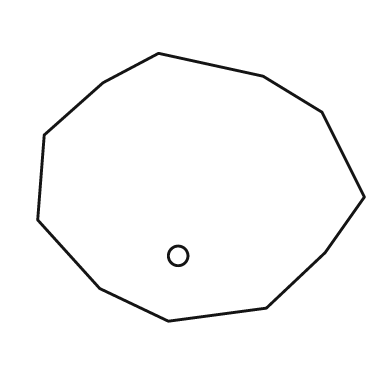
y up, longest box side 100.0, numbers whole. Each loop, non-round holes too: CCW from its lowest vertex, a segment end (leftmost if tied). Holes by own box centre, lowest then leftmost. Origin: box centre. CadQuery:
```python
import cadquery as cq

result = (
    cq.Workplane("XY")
    .moveTo(-10.0, -41.0)
    .lineTo(20.0, -37.0)
    .lineTo(38.0, -20.0)
    .lineTo(50.0, -3.0)
    .lineTo(37.0, 23.0)
    .lineTo(19.0, 34.0)
    .lineTo(-13.0, 41.0)
    .lineTo(-30.0, 32.0)
    .lineTo(-48.0, 16.0)
    .lineTo(-50.0, -10.0)
    .lineTo(-31.0, -31.0)
    .close()
    .moveTo(-7.0, -21.0)
    .circle(3.0)
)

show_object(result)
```